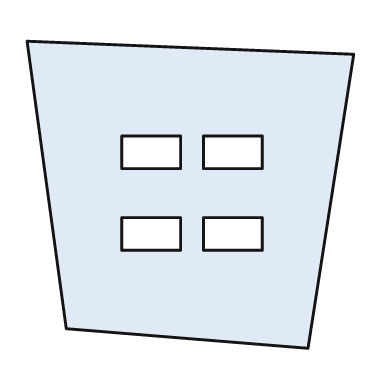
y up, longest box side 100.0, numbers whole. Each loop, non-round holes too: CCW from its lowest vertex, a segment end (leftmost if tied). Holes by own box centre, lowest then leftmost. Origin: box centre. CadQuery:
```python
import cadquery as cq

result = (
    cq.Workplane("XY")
    .moveTo(36.0, -47.0)
    .lineTo(50.0, 43.0)
    .lineTo(-50.0, 47.0)
    .lineTo(-38.0, -41.0)
    .close()
    .moveTo(-21.0, -17.0)
    .lineTo(-3.0, -17.0)
    .lineTo(-3.0, -7.0)
    .lineTo(-21.0, -7.0)
    .close()
    .moveTo(4.0, -17.0)
    .lineTo(22.0, -17.0)
    .lineTo(22.0, -7.0)
    .lineTo(4.0, -7.0)
    .close()
    .moveTo(-21.0, 8.0)
    .lineTo(-3.0, 8.0)
    .lineTo(-3.0, 18.0)
    .lineTo(-21.0, 18.0)
    .close()
    .moveTo(4.0, 8.0)
    .lineTo(22.0, 8.0)
    .lineTo(22.0, 18.0)
    .lineTo(4.0, 18.0)
    .close()
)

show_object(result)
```